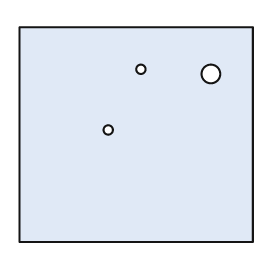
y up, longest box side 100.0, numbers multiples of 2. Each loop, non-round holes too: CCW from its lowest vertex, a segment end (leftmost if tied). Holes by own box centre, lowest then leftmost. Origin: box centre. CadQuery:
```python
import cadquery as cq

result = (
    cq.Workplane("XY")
    .moveTo(-50.0, -46.0)
    .lineTo(50.0, -46.0)
    .lineTo(50.0, 46.0)
    .lineTo(-50.0, 46.0)
    .close()
    .moveTo(-12.0, 2.0)
    .circle(2.0)
    .moveTo(32.0, 26.0)
    .circle(4.0)
    .moveTo(2.0, 28.0)
    .circle(2.0)
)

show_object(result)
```